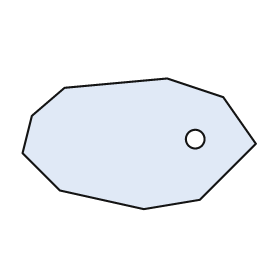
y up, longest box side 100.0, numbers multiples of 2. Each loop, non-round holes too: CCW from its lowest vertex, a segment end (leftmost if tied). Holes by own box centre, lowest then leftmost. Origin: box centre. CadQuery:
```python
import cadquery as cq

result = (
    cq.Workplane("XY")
    .moveTo(2.0, -28.0)
    .lineTo(26.0, -24.0)
    .lineTo(50.0, 0.0)
    .lineTo(36.0, 20.0)
    .lineTo(12.0, 28.0)
    .lineTo(-32.0, 24.0)
    .lineTo(-46.0, 12.0)
    .lineTo(-50.0, -4.0)
    .lineTo(-34.0, -20.0)
    .close()
    .moveTo(24.0, 2.0)
    .circle(4.0)
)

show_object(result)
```